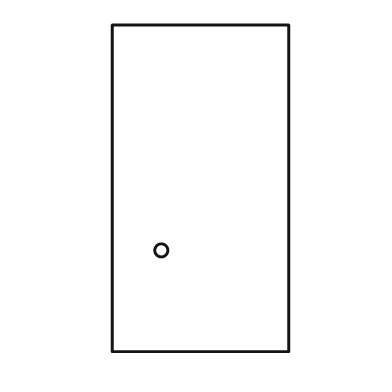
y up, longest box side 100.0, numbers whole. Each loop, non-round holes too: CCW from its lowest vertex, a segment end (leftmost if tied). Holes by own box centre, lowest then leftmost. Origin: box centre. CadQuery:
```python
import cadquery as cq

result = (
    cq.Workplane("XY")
    .moveTo(-27.0, -50.0)
    .lineTo(27.0, -50.0)
    .lineTo(27.0, 50.0)
    .lineTo(-27.0, 50.0)
    .close()
    .moveTo(-12.0, -19.0)
    .circle(2.0)
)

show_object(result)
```